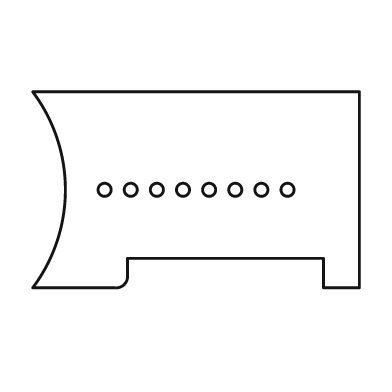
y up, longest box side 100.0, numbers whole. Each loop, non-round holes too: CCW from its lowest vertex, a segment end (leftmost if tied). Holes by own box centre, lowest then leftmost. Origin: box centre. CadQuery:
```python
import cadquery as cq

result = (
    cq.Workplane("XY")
    .moveTo(-50.0, -30.0)
    .lineTo(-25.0, -30.0)
    .threePointArc((-22.0, -29.0), (-21.0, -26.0))
    .lineTo(-21.0, -21.0)
    .lineTo(39.0, -21.0)
    .lineTo(39.0, -30.0)
    .lineTo(50.0, -30.0)
    .lineTo(50.0, 30.0)
    .lineTo(-50.0, 30.0)
    .threePointArc((-40.0, 0.0), (-50.0, -30.0))
    .close()
    .moveTo(-28.0, 0.0)
    .circle(2.0)
    .moveTo(-20.0, 0.0)
    .circle(2.0)
    .moveTo(-12.0, 0.0)
    .circle(2.0)
    .moveTo(-4.0, 0.0)
    .circle(2.0)
    .moveTo(4.0, 0.0)
    .circle(2.0)
    .moveTo(12.0, 0.0)
    .circle(2.0)
    .moveTo(20.0, 0.0)
    .circle(2.0)
    .moveTo(28.0, 0.0)
    .circle(2.0)
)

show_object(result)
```